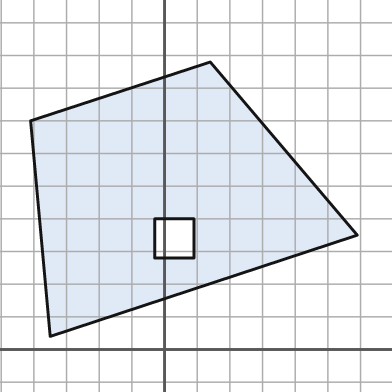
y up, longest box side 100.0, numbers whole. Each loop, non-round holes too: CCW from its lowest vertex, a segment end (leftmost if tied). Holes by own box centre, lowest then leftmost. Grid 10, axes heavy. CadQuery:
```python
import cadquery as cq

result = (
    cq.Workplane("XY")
    .moveTo(-35.0, 4.0)
    .lineTo(59.0, 35.0)
    .lineTo(14.0, 88.0)
    .lineTo(-41.0, 70.0)
    .close()
    .moveTo(-3.0, 28.0)
    .lineTo(9.0, 28.0)
    .lineTo(9.0, 40.0)
    .lineTo(-3.0, 40.0)
    .close()
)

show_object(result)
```